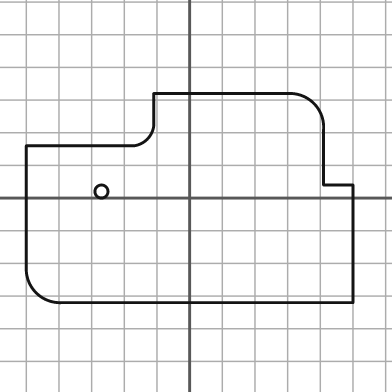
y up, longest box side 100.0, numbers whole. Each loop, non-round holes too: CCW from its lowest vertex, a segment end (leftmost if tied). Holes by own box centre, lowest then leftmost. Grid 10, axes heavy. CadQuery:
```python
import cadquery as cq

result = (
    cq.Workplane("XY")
    .moveTo(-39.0, -32.0)
    .lineTo(50.0, -32.0)
    .lineTo(50.0, 4.0)
    .lineTo(41.0, 4.0)
    .lineTo(41.0, 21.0)
    .threePointArc((38.0, 29.0), (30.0, 32.0))
    .lineTo(-11.0, 32.0)
    .lineTo(-11.0, 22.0)
    .threePointArc((-13.0, 18.0), (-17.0, 16.0))
    .lineTo(-50.0, 16.0)
    .lineTo(-50.0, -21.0)
    .threePointArc((-47.0, -29.0), (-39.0, -32.0))
    .close()
    .moveTo(-27.0, 2.0)
    .circle(2.0)
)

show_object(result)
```